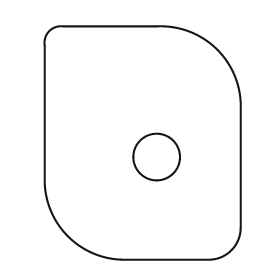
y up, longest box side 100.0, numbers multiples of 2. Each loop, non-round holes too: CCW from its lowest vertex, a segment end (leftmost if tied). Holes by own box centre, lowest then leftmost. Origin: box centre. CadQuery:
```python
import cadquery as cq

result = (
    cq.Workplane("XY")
    .moveTo(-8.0, -50.0)
    .lineTo(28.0, -50.0)
    .threePointArc((38.0, -46.0), (42.0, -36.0))
    .lineTo(42.0, 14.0)
    .threePointArc((32.0, 40.0), (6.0, 50.0))
    .lineTo(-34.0, 50.0)
    .threePointArc((-40.0, 48.0), (-42.0, 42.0))
    .lineTo(-42.0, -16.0)
    .threePointArc((-32.0, -40.0), (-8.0, -50.0))
    .close()
    .moveTo(6.0, -6.0)
    .circle(10.0)
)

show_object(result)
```